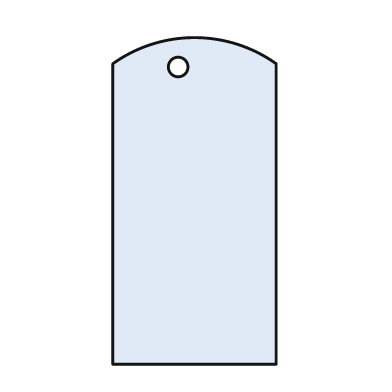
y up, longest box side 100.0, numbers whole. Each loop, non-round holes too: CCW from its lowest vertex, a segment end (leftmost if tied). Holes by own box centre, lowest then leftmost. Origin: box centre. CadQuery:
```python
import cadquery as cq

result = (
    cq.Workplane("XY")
    .moveTo(-25.0, -50.0)
    .lineTo(25.0, -50.0)
    .lineTo(25.0, 42.0)
    .threePointArc((0.0, 50.0), (-25.0, 42.0))
    .close()
    .moveTo(-5.0, 41.0)
    .circle(3.0)
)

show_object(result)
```